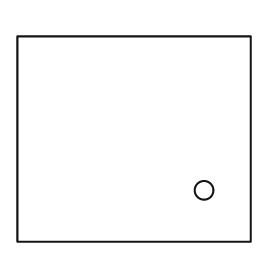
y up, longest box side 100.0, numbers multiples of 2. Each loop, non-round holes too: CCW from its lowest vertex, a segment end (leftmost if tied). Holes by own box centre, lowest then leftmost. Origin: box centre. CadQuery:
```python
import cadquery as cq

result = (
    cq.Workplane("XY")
    .moveTo(-50.0, -44.0)
    .lineTo(50.0, -44.0)
    .lineTo(50.0, 44.0)
    .lineTo(-50.0, 44.0)
    .close()
    .moveTo(30.0, -22.0)
    .circle(4.0)
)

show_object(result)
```